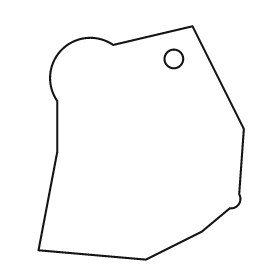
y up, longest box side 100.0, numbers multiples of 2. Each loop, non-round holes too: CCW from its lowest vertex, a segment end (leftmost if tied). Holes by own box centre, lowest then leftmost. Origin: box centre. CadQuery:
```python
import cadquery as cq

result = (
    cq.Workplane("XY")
    .moveTo(2.0, -50.0)
    .lineTo(26.0, -38.0)
    .lineTo(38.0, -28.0)
    .threePointArc((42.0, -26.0), (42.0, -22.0))
    .lineTo(44.0, 6.0)
    .lineTo(22.0, 50.0)
    .lineTo(-12.0, 42.0)
    .threePointArc((-34.0, 40.0), (-36.0, 18.0))
    .lineTo(-36.0, -4.0)
    .lineTo(-44.0, -46.0)
    .close()
    .moveTo(14.0, 36.0)
    .circle(4.0)
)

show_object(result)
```